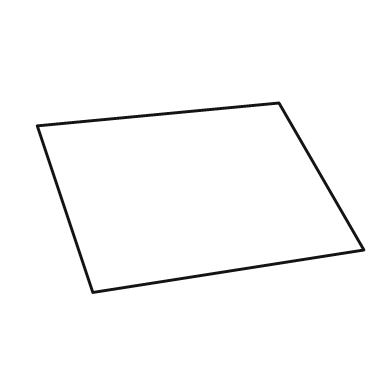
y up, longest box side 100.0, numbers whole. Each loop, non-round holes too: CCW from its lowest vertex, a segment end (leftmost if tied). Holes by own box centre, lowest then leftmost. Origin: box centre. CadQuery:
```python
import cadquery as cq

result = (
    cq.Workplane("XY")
    .moveTo(-33.0, -29.0)
    .lineTo(50.0, -16.0)
    .lineTo(24.0, 29.0)
    .lineTo(-50.0, 22.0)
    .close()
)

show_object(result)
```